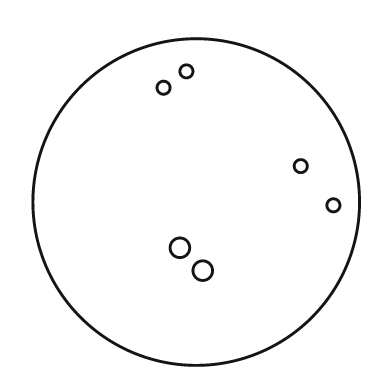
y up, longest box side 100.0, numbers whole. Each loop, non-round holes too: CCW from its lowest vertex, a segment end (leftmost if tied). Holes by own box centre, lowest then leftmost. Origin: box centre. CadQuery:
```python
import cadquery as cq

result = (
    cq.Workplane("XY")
    .moveTo(0.0, 0.0)
    .circle(50.0)
    .moveTo(2.0, -21.0)
    .circle(3.0)
    .moveTo(-5.0, -14.0)
    .circle(3.0)
    .moveTo(42.0, -1.0)
    .circle(2.0)
    .moveTo(32.0, 11.0)
    .circle(2.0)
    .moveTo(-10.0, 35.0)
    .circle(2.0)
    .moveTo(-3.0, 40.0)
    .circle(2.0)
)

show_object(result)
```